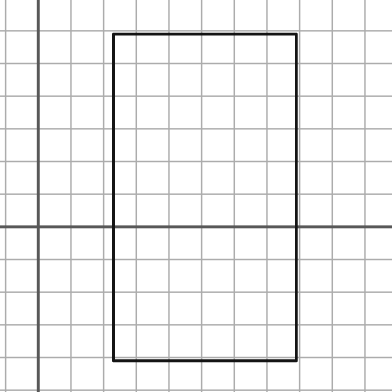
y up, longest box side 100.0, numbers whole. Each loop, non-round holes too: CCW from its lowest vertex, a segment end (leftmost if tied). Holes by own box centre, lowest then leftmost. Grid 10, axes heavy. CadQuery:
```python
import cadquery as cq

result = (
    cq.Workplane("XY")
    .moveTo(23.0, -41.0)
    .lineTo(79.0, -41.0)
    .lineTo(79.0, 59.0)
    .lineTo(23.0, 59.0)
    .close()
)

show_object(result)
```